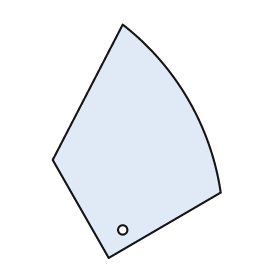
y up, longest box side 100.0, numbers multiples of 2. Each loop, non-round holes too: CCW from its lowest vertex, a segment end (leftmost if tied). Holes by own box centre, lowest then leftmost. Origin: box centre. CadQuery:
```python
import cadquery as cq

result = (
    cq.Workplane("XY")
    .moveTo(-12.0, -50.0)
    .lineTo(36.0, -22.0)
    .threePointArc((22.0, 18.0), (-6.0, 50.0))
    .lineTo(-36.0, -8.0)
    .close()
    .moveTo(-6.0, -38.0)
    .circle(2.0)
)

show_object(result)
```